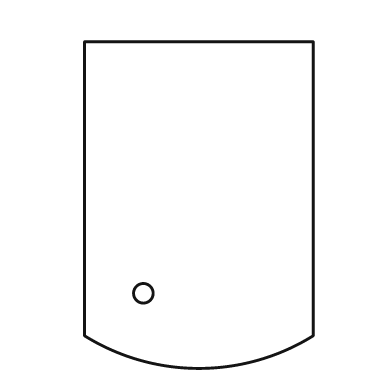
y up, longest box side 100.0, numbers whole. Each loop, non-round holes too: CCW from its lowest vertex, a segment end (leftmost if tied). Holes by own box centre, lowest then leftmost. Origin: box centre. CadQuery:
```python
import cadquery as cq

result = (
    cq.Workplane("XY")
    .moveTo(-35.0, -40.0)
    .threePointArc((0.0, -50.0), (35.0, -40.0))
    .lineTo(35.0, 50.0)
    .lineTo(-35.0, 50.0)
    .close()
    .moveTo(-17.0, -27.0)
    .circle(3.0)
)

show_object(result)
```